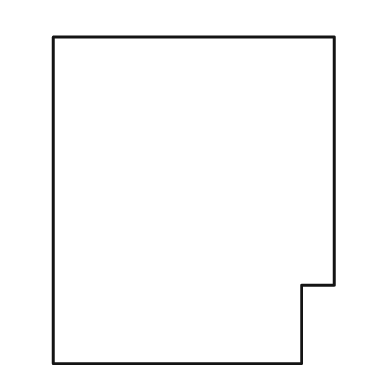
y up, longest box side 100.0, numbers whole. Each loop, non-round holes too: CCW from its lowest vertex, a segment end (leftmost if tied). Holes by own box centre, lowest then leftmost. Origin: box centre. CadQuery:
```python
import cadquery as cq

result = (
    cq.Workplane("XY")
    .moveTo(-43.0, -50.0)
    .lineTo(33.0, -50.0)
    .lineTo(33.0, -26.0)
    .lineTo(43.0, -26.0)
    .lineTo(43.0, 50.0)
    .lineTo(-43.0, 50.0)
    .close()
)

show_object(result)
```